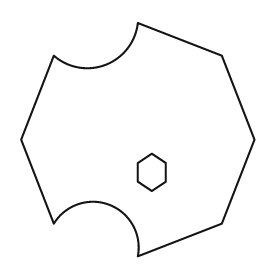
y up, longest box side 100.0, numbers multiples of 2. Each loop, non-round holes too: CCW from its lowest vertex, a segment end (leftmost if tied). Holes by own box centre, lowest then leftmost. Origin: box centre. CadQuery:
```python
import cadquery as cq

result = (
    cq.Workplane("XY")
    .moveTo(0.0, -50.0)
    .lineTo(36.0, -36.0)
    .lineTo(50.0, 0.0)
    .lineTo(36.0, 36.0)
    .lineTo(0.0, 50.0)
    .threePointArc((-14.0, 32.0), (-36.0, 36.0))
    .lineTo(-50.0, 0.0)
    .lineTo(-36.0, -36.0)
    .threePointArc((-12.0, -28.0), (0.0, -50.0))
    .close()
    .moveTo(6.0, -22.0)
    .lineTo(12.0, -18.0)
    .lineTo(12.0, -10.0)
    .lineTo(6.0, -6.0)
    .lineTo(0.0, -10.0)
    .lineTo(0.0, -18.0)
    .close()
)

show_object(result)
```